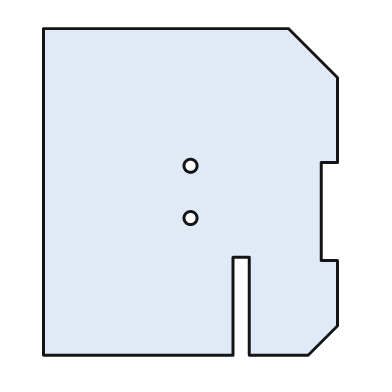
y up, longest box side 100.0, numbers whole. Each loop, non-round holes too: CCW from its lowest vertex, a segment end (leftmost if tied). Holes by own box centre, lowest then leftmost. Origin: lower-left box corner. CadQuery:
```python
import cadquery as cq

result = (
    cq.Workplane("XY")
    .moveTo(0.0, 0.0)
    .lineTo(58.0, 0.0)
    .lineTo(58.0, 30.0)
    .lineTo(63.0, 30.0)
    .lineTo(63.0, 0.0)
    .lineTo(81.0, 0.0)
    .lineTo(90.0, 9.0)
    .lineTo(90.0, 29.0)
    .lineTo(85.0, 29.0)
    .lineTo(85.0, 59.0)
    .lineTo(90.0, 59.0)
    .lineTo(90.0, 85.0)
    .lineTo(75.0, 100.0)
    .lineTo(0.0, 100.0)
    .close()
    .moveTo(45.0, 42.0)
    .circle(2.0)
    .moveTo(45.0, 58.0)
    .circle(2.0)
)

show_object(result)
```